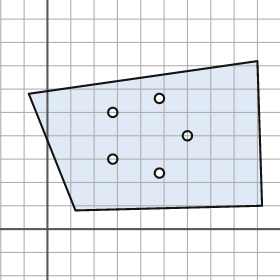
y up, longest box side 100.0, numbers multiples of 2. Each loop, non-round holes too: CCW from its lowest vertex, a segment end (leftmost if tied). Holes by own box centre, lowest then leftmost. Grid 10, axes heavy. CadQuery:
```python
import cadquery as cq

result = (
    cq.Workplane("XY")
    .moveTo(12.0, 8.0)
    .lineTo(92.0, 10.0)
    .lineTo(90.0, 72.0)
    .lineTo(-8.0, 58.0)
    .close()
    .moveTo(48.0, 24.0)
    .circle(2.0)
    .moveTo(28.0, 30.0)
    .circle(2.0)
    .moveTo(60.0, 40.0)
    .circle(2.0)
    .moveTo(28.0, 50.0)
    .circle(2.0)
    .moveTo(48.0, 56.0)
    .circle(2.0)
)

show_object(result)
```